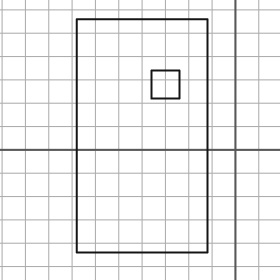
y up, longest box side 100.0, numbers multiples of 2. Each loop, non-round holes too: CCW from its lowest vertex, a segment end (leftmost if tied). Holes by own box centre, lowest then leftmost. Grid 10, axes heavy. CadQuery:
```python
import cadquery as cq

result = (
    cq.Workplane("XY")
    .moveTo(-68.0, -44.0)
    .lineTo(-12.0, -44.0)
    .lineTo(-12.0, 56.0)
    .lineTo(-68.0, 56.0)
    .close()
    .moveTo(-36.0, 22.0)
    .lineTo(-24.0, 22.0)
    .lineTo(-24.0, 34.0)
    .lineTo(-36.0, 34.0)
    .close()
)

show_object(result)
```